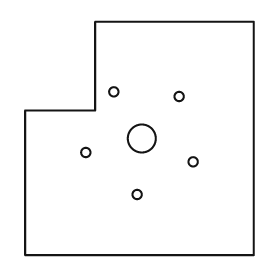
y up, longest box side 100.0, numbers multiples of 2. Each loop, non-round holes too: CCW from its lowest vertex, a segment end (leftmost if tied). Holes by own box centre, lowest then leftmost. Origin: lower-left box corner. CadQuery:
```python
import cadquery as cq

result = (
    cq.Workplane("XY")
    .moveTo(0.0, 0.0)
    .lineTo(98.0, 0.0)
    .lineTo(98.0, 100.0)
    .lineTo(30.0, 100.0)
    .lineTo(30.0, 62.0)
    .lineTo(0.0, 62.0)
    .close()
    .moveTo(48.0, 26.0)
    .circle(2.0)
    .moveTo(72.0, 40.0)
    .circle(2.0)
    .moveTo(26.0, 44.0)
    .circle(2.0)
    .moveTo(50.0, 50.0)
    .circle(6.0)
    .moveTo(66.0, 68.0)
    .circle(2.0)
    .moveTo(38.0, 70.0)
    .circle(2.0)
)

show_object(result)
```